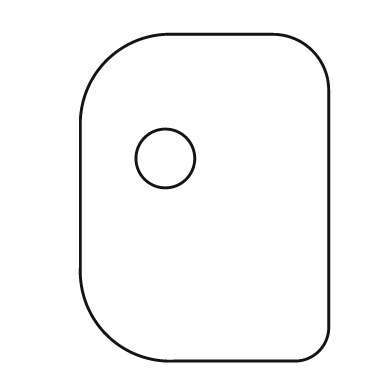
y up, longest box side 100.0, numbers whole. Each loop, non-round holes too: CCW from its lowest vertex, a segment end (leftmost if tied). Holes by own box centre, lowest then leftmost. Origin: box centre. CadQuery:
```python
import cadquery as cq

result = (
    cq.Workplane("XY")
    .moveTo(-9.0, -50.0)
    .lineTo(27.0, -50.0)
    .threePointArc((35.0, -47.0), (38.0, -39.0))
    .lineTo(38.0, 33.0)
    .threePointArc((33.0, 45.0), (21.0, 50.0))
    .lineTo(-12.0, 50.0)
    .threePointArc((-30.0, 42.0), (-38.0, 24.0))
    .lineTo(-38.0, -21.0)
    .threePointArc((-30.0, -42.0), (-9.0, -50.0))
    .close()
    .moveTo(-12.0, 12.0)
    .circle(9.0)
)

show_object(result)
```